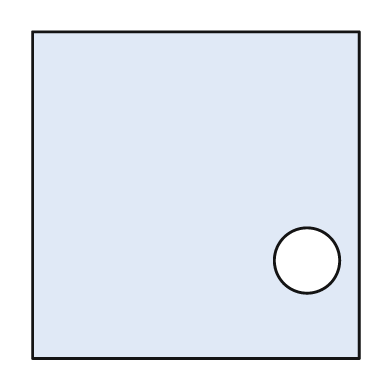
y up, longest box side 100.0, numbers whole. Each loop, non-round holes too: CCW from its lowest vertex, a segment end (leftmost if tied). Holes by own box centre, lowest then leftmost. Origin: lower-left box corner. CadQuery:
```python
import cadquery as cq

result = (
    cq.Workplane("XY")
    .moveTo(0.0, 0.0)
    .lineTo(100.0, 0.0)
    .lineTo(100.0, 100.0)
    .lineTo(0.0, 100.0)
    .close()
    .moveTo(84.0, 30.0)
    .circle(10.0)
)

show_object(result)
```